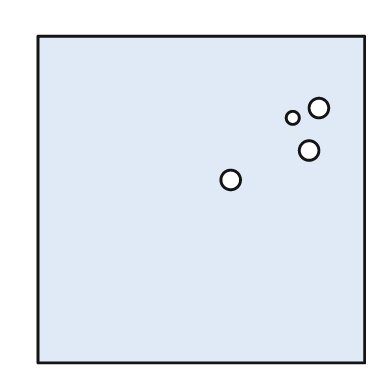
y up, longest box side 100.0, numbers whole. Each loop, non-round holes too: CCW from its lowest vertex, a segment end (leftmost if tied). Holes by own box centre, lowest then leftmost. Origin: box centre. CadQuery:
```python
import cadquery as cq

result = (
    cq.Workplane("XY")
    .moveTo(-50.0, -50.0)
    .lineTo(50.0, -50.0)
    .lineTo(50.0, 50.0)
    .lineTo(-50.0, 50.0)
    .close()
    .moveTo(9.0, 6.0)
    .circle(3.0)
    .moveTo(33.0, 15.0)
    .circle(3.0)
    .moveTo(28.0, 25.0)
    .circle(2.0)
    .moveTo(36.0, 28.0)
    .circle(3.0)
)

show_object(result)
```